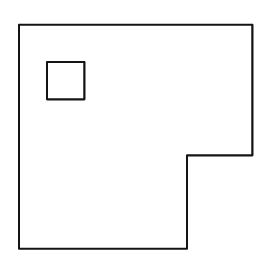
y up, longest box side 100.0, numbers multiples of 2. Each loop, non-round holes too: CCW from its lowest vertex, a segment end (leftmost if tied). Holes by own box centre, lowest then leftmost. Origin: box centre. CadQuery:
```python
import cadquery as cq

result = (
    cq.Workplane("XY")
    .moveTo(-50.0, -48.0)
    .lineTo(22.0, -48.0)
    .lineTo(22.0, -8.0)
    .lineTo(50.0, -8.0)
    .lineTo(50.0, 48.0)
    .lineTo(-50.0, 48.0)
    .close()
    .moveTo(-38.0, 16.0)
    .lineTo(-22.0, 16.0)
    .lineTo(-22.0, 32.0)
    .lineTo(-38.0, 32.0)
    .close()
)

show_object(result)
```